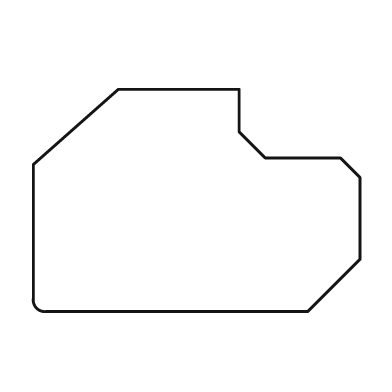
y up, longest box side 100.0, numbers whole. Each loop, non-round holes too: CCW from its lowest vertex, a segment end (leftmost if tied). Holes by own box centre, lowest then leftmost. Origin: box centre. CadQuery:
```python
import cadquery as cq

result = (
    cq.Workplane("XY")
    .moveTo(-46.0, -34.0)
    .lineTo(34.0, -34.0)
    .lineTo(50.0, -18.0)
    .lineTo(50.0, 7.0)
    .lineTo(44.0, 13.0)
    .lineTo(21.0, 13.0)
    .lineTo(13.0, 21.0)
    .lineTo(13.0, 34.0)
    .lineTo(-24.0, 34.0)
    .lineTo(-50.0, 11.0)
    .lineTo(-50.0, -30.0)
    .threePointArc((-49.0, -33.0), (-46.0, -34.0))
    .close()
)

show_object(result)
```